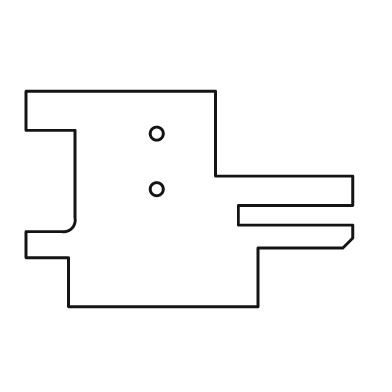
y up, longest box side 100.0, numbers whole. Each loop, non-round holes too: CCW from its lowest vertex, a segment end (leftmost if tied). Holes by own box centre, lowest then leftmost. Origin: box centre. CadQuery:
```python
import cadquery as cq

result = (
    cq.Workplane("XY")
    .moveTo(-37.0, -33.0)
    .lineTo(21.0, -33.0)
    .lineTo(21.0, -15.0)
    .lineTo(47.0, -15.0)
    .lineTo(50.0, -12.0)
    .lineTo(50.0, -8.0)
    .lineTo(15.0, -8.0)
    .lineTo(15.0, -2.0)
    .lineTo(50.0, -2.0)
    .lineTo(50.0, 7.0)
    .lineTo(8.0, 7.0)
    .lineTo(8.0, 33.0)
    .lineTo(-50.0, 33.0)
    .lineTo(-50.0, 21.0)
    .lineTo(-35.0, 21.0)
    .lineTo(-35.0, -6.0)
    .threePointArc((-36.0, -9.0), (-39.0, -10.0))
    .lineTo(-50.0, -10.0)
    .lineTo(-50.0, -18.0)
    .lineTo(-37.0, -18.0)
    .close()
    .moveTo(-10.0, 3.0)
    .circle(2.0)
    .moveTo(-10.0, 20.0)
    .circle(2.0)
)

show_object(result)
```